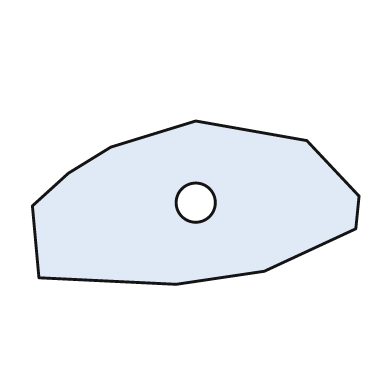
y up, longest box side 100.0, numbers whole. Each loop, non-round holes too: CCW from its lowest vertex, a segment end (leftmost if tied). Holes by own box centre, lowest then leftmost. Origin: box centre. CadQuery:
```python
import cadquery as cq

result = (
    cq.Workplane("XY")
    .moveTo(-6.0, -25.0)
    .lineTo(21.0, -21.0)
    .lineTo(49.0, -8.0)
    .lineTo(50.0, 2.0)
    .lineTo(34.0, 19.0)
    .lineTo(0.0, 25.0)
    .lineTo(-26.0, 17.0)
    .lineTo(-39.0, 9.0)
    .lineTo(-50.0, -1.0)
    .lineTo(-48.0, -23.0)
    .close()
    .moveTo(0.0, 0.0)
    .circle(6.0)
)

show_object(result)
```